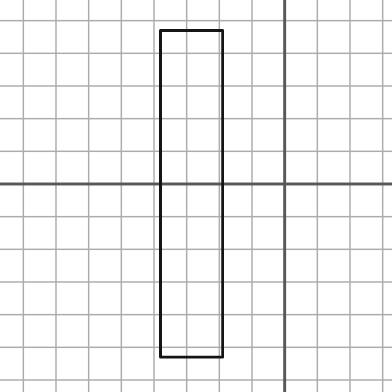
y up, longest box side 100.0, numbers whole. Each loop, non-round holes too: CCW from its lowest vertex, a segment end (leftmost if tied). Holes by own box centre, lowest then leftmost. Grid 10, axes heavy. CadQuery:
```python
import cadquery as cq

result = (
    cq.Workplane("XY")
    .moveTo(-38.0, -53.0)
    .lineTo(-19.0, -53.0)
    .lineTo(-19.0, 47.0)
    .lineTo(-38.0, 47.0)
    .close()
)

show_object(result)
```